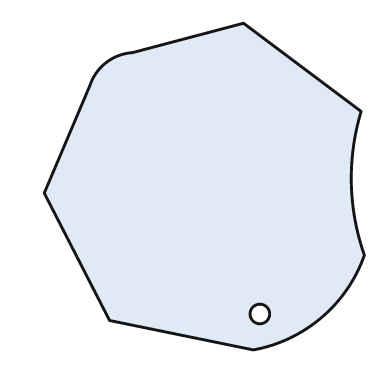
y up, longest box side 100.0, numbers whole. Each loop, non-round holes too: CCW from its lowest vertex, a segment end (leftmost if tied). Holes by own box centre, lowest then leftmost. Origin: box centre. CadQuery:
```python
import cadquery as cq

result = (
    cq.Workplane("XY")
    .moveTo(15.0, -50.0)
    .threePointArc((36.0, -40.0), (49.0, -21.0))
    .threePointArc((45.0, 1.0), (48.0, 23.0))
    .lineTo(12.0, 50.0)
    .lineTo(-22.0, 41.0)
    .threePointArc((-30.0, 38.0), (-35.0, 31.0))
    .lineTo(-49.0, -2.0)
    .lineTo(-29.0, -41.0)
    .close()
    .moveTo(17.0, -39.0)
    .circle(3.0)
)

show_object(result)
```